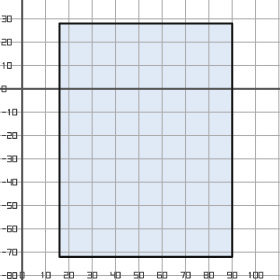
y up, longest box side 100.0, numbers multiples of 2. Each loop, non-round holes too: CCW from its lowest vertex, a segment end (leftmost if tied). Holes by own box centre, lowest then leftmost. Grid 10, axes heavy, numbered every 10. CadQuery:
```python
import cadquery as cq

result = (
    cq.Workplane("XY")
    .moveTo(16.0, -72.0)
    .lineTo(90.0, -72.0)
    .lineTo(90.0, 28.0)
    .lineTo(16.0, 28.0)
    .close()
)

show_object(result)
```